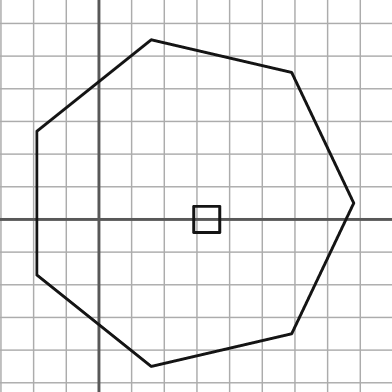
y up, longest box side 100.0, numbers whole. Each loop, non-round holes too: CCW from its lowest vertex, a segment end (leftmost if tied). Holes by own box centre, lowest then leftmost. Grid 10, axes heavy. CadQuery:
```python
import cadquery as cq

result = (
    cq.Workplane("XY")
    .moveTo(16.0, -45.0)
    .lineTo(59.0, -35.0)
    .lineTo(78.0, 5.0)
    .lineTo(59.0, 45.0)
    .lineTo(16.0, 55.0)
    .lineTo(-19.0, 27.0)
    .lineTo(-19.0, -17.0)
    .close()
    .moveTo(29.0, -4.0)
    .lineTo(37.0, -4.0)
    .lineTo(37.0, 4.0)
    .lineTo(29.0, 4.0)
    .close()
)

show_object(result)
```